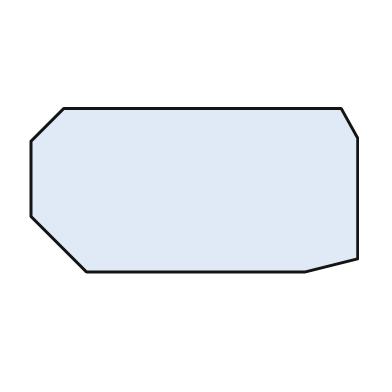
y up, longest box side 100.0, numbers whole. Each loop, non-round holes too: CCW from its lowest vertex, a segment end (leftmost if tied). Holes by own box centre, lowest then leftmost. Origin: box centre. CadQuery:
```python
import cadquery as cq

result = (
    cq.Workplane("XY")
    .moveTo(-33.0, -25.0)
    .lineTo(34.0, -25.0)
    .lineTo(50.0, -21.0)
    .lineTo(50.0, 16.0)
    .lineTo(45.0, 25.0)
    .lineTo(-40.0, 25.0)
    .lineTo(-50.0, 15.0)
    .lineTo(-50.0, -8.0)
    .close()
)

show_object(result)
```